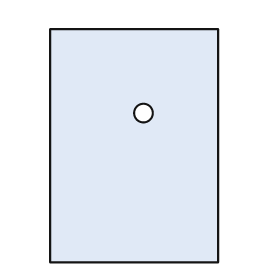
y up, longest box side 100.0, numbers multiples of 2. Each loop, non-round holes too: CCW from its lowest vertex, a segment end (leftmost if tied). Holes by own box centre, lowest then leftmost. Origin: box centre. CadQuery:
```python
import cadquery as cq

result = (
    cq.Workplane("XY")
    .moveTo(-36.0, -50.0)
    .lineTo(36.0, -50.0)
    .lineTo(36.0, 50.0)
    .lineTo(-36.0, 50.0)
    .close()
    .moveTo(4.0, 14.0)
    .circle(4.0)
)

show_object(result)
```